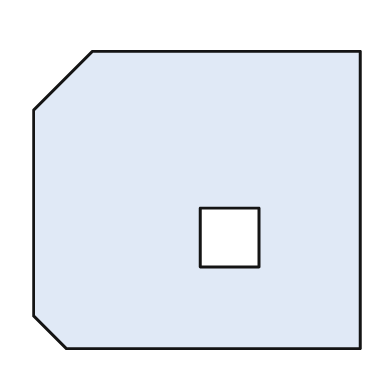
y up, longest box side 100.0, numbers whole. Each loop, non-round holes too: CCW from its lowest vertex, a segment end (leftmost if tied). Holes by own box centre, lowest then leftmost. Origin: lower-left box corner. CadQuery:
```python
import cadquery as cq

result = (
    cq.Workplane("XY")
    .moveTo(10.0, 0.0)
    .lineTo(100.0, 0.0)
    .lineTo(100.0, 91.0)
    .lineTo(18.0, 91.0)
    .lineTo(0.0, 73.0)
    .lineTo(0.0, 10.0)
    .close()
    .moveTo(51.0, 25.0)
    .lineTo(69.0, 25.0)
    .lineTo(69.0, 43.0)
    .lineTo(51.0, 43.0)
    .close()
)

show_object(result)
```